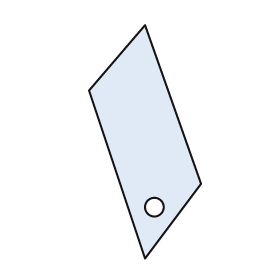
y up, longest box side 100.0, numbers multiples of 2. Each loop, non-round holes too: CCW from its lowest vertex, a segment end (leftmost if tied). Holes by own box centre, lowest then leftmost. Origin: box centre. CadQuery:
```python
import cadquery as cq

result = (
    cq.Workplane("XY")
    .moveTo(0.0, -50.0)
    .lineTo(24.0, -18.0)
    .lineTo(0.0, 50.0)
    .lineTo(-24.0, 22.0)
    .close()
    .moveTo(4.0, -28.0)
    .circle(4.0)
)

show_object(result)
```